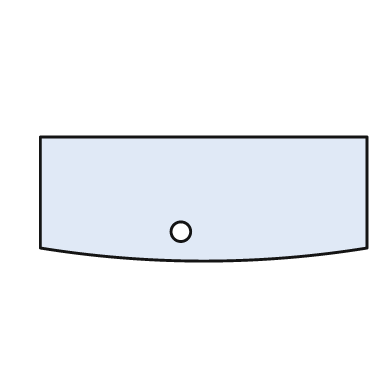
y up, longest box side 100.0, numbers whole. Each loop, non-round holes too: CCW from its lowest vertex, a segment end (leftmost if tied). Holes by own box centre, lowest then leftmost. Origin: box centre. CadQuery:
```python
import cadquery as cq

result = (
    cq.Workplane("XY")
    .moveTo(-50.0, -15.0)
    .threePointArc((0.0, -19.0), (50.0, -15.0))
    .lineTo(50.0, 19.0)
    .lineTo(-50.0, 19.0)
    .close()
    .moveTo(-7.0, -10.0)
    .circle(3.0)
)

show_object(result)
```